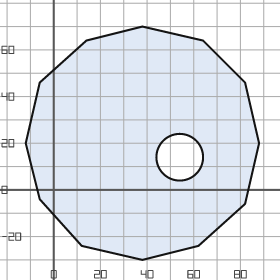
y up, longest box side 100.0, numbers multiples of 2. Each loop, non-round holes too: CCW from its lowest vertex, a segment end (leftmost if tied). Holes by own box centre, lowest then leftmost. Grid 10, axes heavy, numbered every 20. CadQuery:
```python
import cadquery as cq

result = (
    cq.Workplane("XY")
    .moveTo(38.0, -30.0)
    .lineTo(62.0, -24.0)
    .lineTo(82.0, -6.0)
    .lineTo(88.0, 20.0)
    .lineTo(82.0, 46.0)
    .lineTo(64.0, 64.0)
    .lineTo(38.0, 70.0)
    .lineTo(14.0, 64.0)
    .lineTo(-6.0, 46.0)
    .lineTo(-12.0, 20.0)
    .lineTo(-6.0, -4.0)
    .lineTo(12.0, -24.0)
    .close()
    .moveTo(54.0, 14.0)
    .circle(10.0)
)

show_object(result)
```